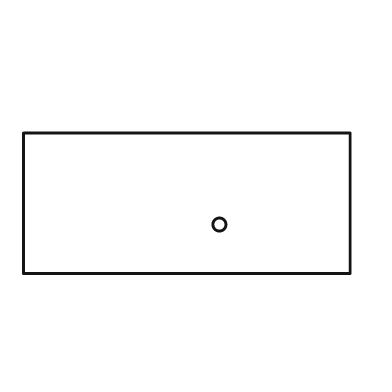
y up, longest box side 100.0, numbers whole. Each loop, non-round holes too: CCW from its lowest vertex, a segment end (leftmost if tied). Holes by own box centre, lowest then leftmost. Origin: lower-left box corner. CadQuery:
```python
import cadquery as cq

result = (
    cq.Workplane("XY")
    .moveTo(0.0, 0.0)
    .lineTo(100.0, 0.0)
    .lineTo(100.0, 43.0)
    .lineTo(0.0, 43.0)
    .close()
    .moveTo(60.0, 15.0)
    .circle(2.0)
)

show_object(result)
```